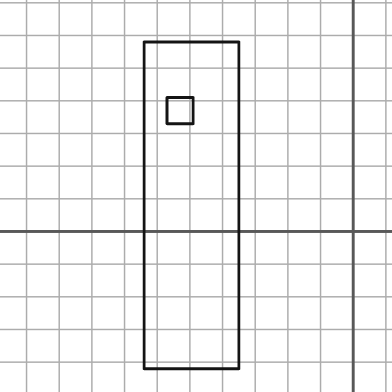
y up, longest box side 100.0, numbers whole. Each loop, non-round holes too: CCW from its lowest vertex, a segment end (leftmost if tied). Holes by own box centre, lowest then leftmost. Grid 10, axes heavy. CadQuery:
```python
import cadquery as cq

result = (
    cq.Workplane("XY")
    .moveTo(-64.0, -42.0)
    .lineTo(-35.0, -42.0)
    .lineTo(-35.0, 58.0)
    .lineTo(-64.0, 58.0)
    .close()
    .moveTo(-57.0, 33.0)
    .lineTo(-49.0, 33.0)
    .lineTo(-49.0, 41.0)
    .lineTo(-57.0, 41.0)
    .close()
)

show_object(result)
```